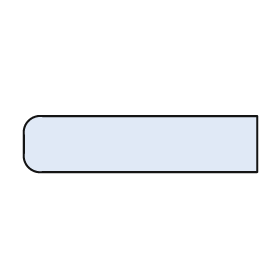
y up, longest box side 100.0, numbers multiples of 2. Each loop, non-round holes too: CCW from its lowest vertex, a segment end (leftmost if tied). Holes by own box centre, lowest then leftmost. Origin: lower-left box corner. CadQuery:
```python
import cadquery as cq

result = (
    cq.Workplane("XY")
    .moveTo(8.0, 0.0)
    .lineTo(100.0, 0.0)
    .lineTo(100.0, 24.0)
    .lineTo(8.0, 24.0)
    .threePointArc((2.0, 22.0), (0.0, 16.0))
    .lineTo(0.0, 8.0)
    .threePointArc((2.0, 2.0), (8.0, 0.0))
    .close()
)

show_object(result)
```